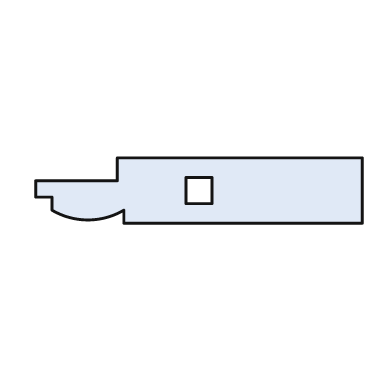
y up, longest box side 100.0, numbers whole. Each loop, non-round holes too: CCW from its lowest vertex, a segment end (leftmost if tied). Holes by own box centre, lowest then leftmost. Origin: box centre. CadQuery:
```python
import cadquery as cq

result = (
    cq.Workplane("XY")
    .moveTo(-23.0, -10.0)
    .lineTo(50.0, -10.0)
    .lineTo(50.0, 10.0)
    .lineTo(-25.0, 10.0)
    .lineTo(-25.0, 3.0)
    .lineTo(-50.0, 3.0)
    .lineTo(-50.0, -2.0)
    .lineTo(-45.0, -2.0)
    .lineTo(-45.0, -6.0)
    .threePointArc((-34.0, -9.0), (-23.0, -6.0))
    .close()
    .moveTo(-4.0, -4.0)
    .lineTo(4.0, -4.0)
    .lineTo(4.0, 4.0)
    .lineTo(-4.0, 4.0)
    .close()
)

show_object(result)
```